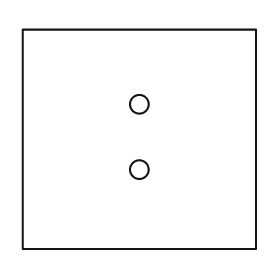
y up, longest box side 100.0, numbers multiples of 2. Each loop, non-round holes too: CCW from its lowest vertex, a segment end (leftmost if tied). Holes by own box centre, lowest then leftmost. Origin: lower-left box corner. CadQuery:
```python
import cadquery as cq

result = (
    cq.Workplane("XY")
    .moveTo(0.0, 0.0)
    .lineTo(100.0, 0.0)
    .lineTo(100.0, 94.0)
    .lineTo(0.0, 94.0)
    .close()
    .moveTo(50.0, 34.0)
    .circle(4.0)
    .moveTo(50.0, 62.0)
    .circle(4.0)
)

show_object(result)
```